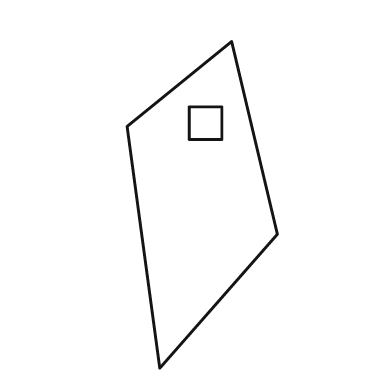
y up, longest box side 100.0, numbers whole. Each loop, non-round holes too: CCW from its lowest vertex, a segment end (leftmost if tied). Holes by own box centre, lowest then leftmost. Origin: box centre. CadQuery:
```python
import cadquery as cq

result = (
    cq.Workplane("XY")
    .moveTo(-13.0, -50.0)
    .lineTo(23.0, -9.0)
    .lineTo(9.0, 50.0)
    .lineTo(-23.0, 24.0)
    .close()
    .moveTo(-4.0, 20.0)
    .lineTo(6.0, 20.0)
    .lineTo(6.0, 30.0)
    .lineTo(-4.0, 30.0)
    .close()
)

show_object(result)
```